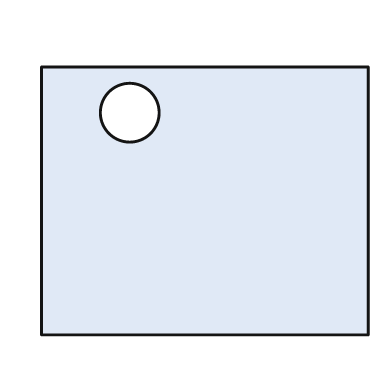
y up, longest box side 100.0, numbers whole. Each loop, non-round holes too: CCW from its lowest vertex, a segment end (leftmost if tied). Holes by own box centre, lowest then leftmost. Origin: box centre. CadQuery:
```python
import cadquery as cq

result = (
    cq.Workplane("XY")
    .moveTo(-50.0, -41.0)
    .lineTo(50.0, -41.0)
    .lineTo(50.0, 41.0)
    .lineTo(-50.0, 41.0)
    .close()
    .moveTo(-23.0, 27.0)
    .circle(9.0)
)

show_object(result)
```